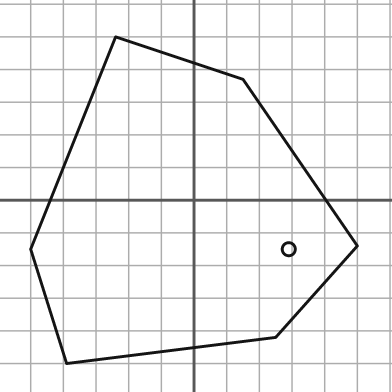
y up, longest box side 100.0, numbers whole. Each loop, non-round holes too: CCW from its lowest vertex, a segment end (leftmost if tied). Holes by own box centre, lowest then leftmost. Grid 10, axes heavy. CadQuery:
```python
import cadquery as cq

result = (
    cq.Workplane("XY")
    .moveTo(-39.0, -50.0)
    .lineTo(25.0, -42.0)
    .lineTo(50.0, -14.0)
    .lineTo(15.0, 37.0)
    .lineTo(-24.0, 50.0)
    .lineTo(-50.0, -15.0)
    .close()
    .moveTo(29.0, -15.0)
    .circle(2.0)
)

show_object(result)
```